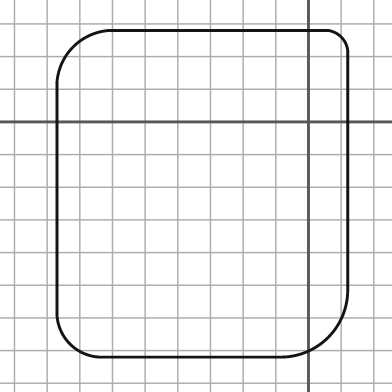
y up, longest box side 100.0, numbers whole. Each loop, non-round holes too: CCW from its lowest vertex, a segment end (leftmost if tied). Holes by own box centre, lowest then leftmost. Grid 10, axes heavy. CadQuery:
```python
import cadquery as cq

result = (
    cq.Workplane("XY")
    .moveTo(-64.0, -72.0)
    .lineTo(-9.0, -72.0)
    .threePointArc((6.0, -66.0), (12.0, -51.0))
    .lineTo(12.0, 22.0)
    .threePointArc((10.0, 26.0), (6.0, 28.0))
    .lineTo(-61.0, 28.0)
    .threePointArc((-72.0, 23.0), (-77.0, 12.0))
    .lineTo(-77.0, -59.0)
    .threePointArc((-73.0, -68.0), (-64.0, -72.0))
    .close()
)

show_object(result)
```